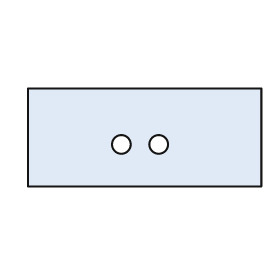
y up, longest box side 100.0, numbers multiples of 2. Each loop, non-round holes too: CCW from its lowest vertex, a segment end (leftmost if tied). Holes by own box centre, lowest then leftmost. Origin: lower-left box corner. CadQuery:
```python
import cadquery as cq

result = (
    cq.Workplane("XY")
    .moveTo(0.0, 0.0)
    .lineTo(100.0, 0.0)
    .lineTo(100.0, 42.0)
    .lineTo(0.0, 42.0)
    .close()
    .moveTo(40.0, 18.0)
    .circle(4.0)
    .moveTo(56.0, 18.0)
    .circle(4.0)
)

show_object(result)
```